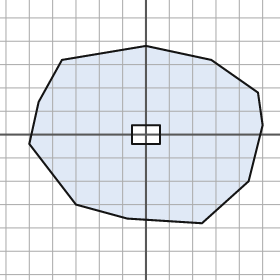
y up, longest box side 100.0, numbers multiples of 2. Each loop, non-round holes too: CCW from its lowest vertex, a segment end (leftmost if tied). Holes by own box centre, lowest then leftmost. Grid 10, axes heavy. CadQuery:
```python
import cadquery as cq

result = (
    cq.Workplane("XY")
    .moveTo(24.0, -38.0)
    .lineTo(44.0, -20.0)
    .lineTo(50.0, 4.0)
    .lineTo(48.0, 18.0)
    .lineTo(28.0, 32.0)
    .lineTo(0.0, 38.0)
    .lineTo(-36.0, 32.0)
    .lineTo(-46.0, 14.0)
    .lineTo(-50.0, -4.0)
    .lineTo(-30.0, -30.0)
    .lineTo(-8.0, -36.0)
    .close()
    .moveTo(-6.0, -4.0)
    .lineTo(6.0, -4.0)
    .lineTo(6.0, 4.0)
    .lineTo(-6.0, 4.0)
    .close()
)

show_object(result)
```